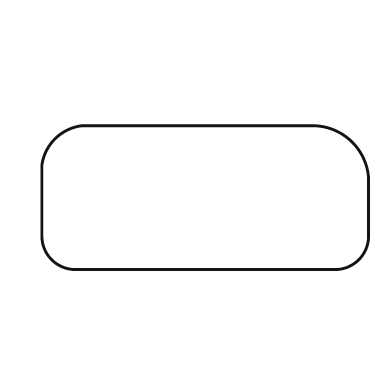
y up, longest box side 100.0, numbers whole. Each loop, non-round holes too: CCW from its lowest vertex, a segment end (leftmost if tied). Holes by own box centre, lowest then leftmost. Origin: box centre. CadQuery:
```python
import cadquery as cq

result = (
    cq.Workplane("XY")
    .moveTo(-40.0, -22.0)
    .lineTo(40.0, -22.0)
    .threePointArc((47.0, -19.0), (50.0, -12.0))
    .lineTo(50.0, 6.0)
    .threePointArc((45.0, 17.0), (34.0, 22.0))
    .lineTo(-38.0, 22.0)
    .threePointArc((-46.0, 18.0), (-50.0, 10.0))
    .lineTo(-50.0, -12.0)
    .threePointArc((-47.0, -19.0), (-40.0, -22.0))
    .close()
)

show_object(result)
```